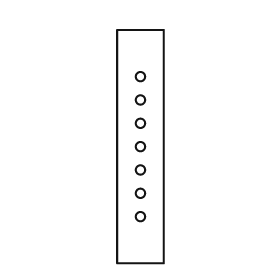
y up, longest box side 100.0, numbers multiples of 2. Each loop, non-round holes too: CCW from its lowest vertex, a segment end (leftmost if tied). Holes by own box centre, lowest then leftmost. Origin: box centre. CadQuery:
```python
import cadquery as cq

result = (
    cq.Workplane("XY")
    .moveTo(-10.0, -50.0)
    .lineTo(10.0, -50.0)
    .lineTo(10.0, 50.0)
    .lineTo(-10.0, 50.0)
    .close()
    .moveTo(0.0, -30.0)
    .circle(2.0)
    .moveTo(0.0, -20.0)
    .circle(2.0)
    .moveTo(0.0, -10.0)
    .circle(2.0)
    .moveTo(0.0, 0.0)
    .circle(2.0)
    .moveTo(0.0, 10.0)
    .circle(2.0)
    .moveTo(0.0, 20.0)
    .circle(2.0)
    .moveTo(0.0, 30.0)
    .circle(2.0)
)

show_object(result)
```